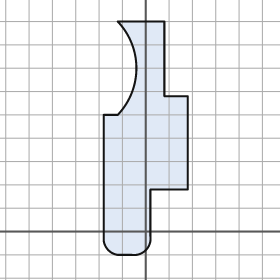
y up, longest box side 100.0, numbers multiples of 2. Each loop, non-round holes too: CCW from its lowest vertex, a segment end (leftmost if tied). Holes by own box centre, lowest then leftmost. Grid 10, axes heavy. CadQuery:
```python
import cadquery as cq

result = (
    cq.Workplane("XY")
    .moveTo(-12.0, -10.0)
    .lineTo(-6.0, -10.0)
    .threePointArc((0.0, -8.0), (2.0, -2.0))
    .lineTo(2.0, 18.0)
    .lineTo(18.0, 18.0)
    .lineTo(18.0, 58.0)
    .lineTo(8.0, 58.0)
    .lineTo(8.0, 90.0)
    .lineTo(-12.0, 90.0)
    .threePointArc((-4.0, 70.0), (-12.0, 50.0))
    .lineTo(-18.0, 50.0)
    .lineTo(-18.0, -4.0)
    .threePointArc((-16.0, -8.0), (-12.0, -10.0))
    .close()
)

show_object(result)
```